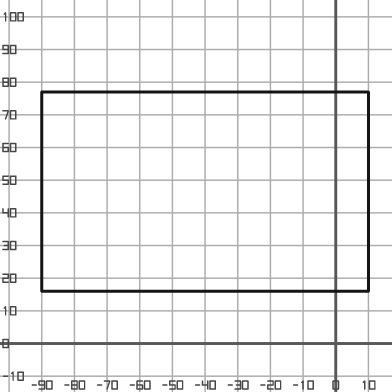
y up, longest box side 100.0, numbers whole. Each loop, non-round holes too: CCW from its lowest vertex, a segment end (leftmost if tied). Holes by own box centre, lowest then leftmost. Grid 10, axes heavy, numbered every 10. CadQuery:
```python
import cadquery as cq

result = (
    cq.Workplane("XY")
    .moveTo(-90.0, 16.0)
    .lineTo(10.0, 16.0)
    .lineTo(10.0, 77.0)
    .lineTo(-90.0, 77.0)
    .close()
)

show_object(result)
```